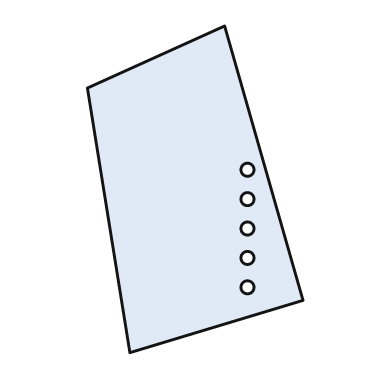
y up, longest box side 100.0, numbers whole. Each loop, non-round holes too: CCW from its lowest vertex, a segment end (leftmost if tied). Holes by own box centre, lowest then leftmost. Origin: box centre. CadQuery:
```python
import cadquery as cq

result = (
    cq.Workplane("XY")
    .moveTo(-20.0, -50.0)
    .lineTo(33.0, -34.0)
    .lineTo(9.0, 50.0)
    .lineTo(-33.0, 31.0)
    .close()
    .moveTo(16.0, -30.0)
    .circle(2.0)
    .moveTo(16.0, -21.0)
    .circle(2.0)
    .moveTo(16.0, -12.0)
    .circle(2.0)
    .moveTo(16.0, -3.0)
    .circle(2.0)
    .moveTo(16.0, 6.0)
    .circle(2.0)
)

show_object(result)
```